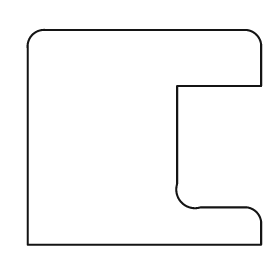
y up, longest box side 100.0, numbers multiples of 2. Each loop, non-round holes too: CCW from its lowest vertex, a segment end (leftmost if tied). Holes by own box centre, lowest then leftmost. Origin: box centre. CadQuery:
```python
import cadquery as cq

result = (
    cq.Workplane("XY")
    .moveTo(-50.0, -46.0)
    .lineTo(50.0, -46.0)
    .lineTo(50.0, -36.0)
    .threePointArc((48.0, -32.0), (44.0, -30.0))
    .lineTo(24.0, -30.0)
    .threePointArc((16.0, -28.0), (14.0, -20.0))
    .lineTo(14.0, 22.0)
    .lineTo(50.0, 22.0)
    .lineTo(50.0, 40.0)
    .threePointArc((48.0, 44.0), (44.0, 46.0))
    .lineTo(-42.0, 46.0)
    .threePointArc((-48.0, 44.0), (-50.0, 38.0))
    .close()
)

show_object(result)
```